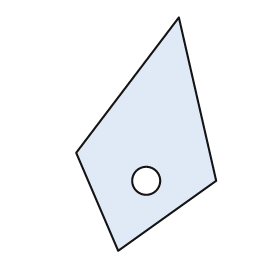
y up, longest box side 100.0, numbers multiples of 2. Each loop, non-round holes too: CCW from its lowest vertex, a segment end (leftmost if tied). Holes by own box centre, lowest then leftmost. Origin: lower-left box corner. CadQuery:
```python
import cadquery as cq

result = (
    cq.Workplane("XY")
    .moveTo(18.0, 0.0)
    .lineTo(60.0, 30.0)
    .lineTo(44.0, 100.0)
    .lineTo(0.0, 42.0)
    .close()
    .moveTo(30.0, 30.0)
    .circle(6.0)
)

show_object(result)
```